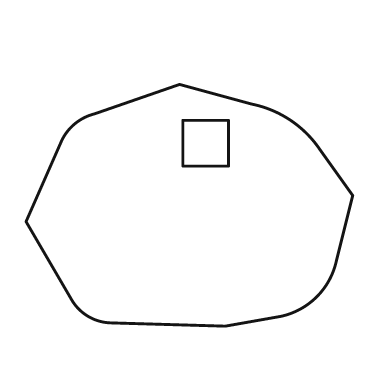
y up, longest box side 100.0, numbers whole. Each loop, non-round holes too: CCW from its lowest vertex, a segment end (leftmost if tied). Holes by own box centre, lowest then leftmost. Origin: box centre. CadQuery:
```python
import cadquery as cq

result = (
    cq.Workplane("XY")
    .moveTo(11.0, -37.0)
    .lineTo(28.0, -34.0)
    .threePointArc((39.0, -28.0), (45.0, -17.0))
    .lineTo(50.0, 3.0)
    .lineTo(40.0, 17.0)
    .threePointArc((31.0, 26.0), (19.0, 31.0))
    .lineTo(-3.0, 37.0)
    .lineTo(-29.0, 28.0)
    .threePointArc((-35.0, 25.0), (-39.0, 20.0))
    .lineTo(-50.0, -5.0)
    .lineTo(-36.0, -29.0)
    .threePointArc((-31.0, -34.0), (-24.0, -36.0))
    .close()
    .moveTo(-2.0, 12.0)
    .lineTo(12.0, 12.0)
    .lineTo(12.0, 26.0)
    .lineTo(-2.0, 26.0)
    .close()
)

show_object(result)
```